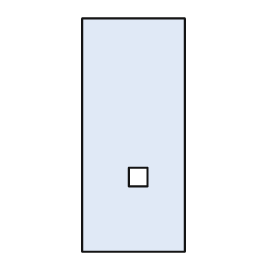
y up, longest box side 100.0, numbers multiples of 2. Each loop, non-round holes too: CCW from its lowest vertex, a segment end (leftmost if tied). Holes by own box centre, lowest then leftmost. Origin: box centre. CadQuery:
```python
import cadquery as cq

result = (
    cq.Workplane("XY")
    .moveTo(-22.0, -50.0)
    .lineTo(22.0, -50.0)
    .lineTo(22.0, 50.0)
    .lineTo(-22.0, 50.0)
    .close()
    .moveTo(-2.0, -22.0)
    .lineTo(6.0, -22.0)
    .lineTo(6.0, -14.0)
    .lineTo(-2.0, -14.0)
    .close()
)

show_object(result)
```